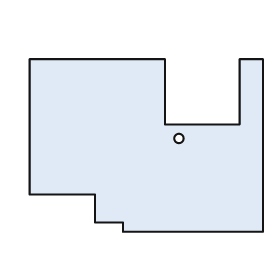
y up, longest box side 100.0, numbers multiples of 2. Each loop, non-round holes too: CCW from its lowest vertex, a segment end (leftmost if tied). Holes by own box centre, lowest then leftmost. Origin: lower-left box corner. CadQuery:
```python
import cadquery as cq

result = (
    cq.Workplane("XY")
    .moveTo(40.0, 0.0)
    .lineTo(100.0, 0.0)
    .lineTo(100.0, 74.0)
    .lineTo(90.0, 74.0)
    .lineTo(90.0, 46.0)
    .lineTo(58.0, 46.0)
    .lineTo(58.0, 74.0)
    .lineTo(0.0, 74.0)
    .lineTo(0.0, 16.0)
    .lineTo(28.0, 16.0)
    .lineTo(28.0, 4.0)
    .lineTo(40.0, 4.0)
    .close()
    .moveTo(64.0, 40.0)
    .circle(2.0)
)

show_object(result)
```